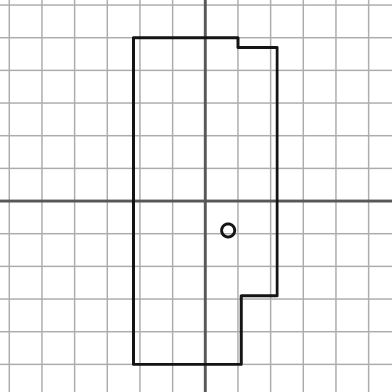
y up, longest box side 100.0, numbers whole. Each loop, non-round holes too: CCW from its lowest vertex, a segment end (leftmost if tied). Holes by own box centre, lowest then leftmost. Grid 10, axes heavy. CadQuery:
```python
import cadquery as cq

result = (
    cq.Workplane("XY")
    .moveTo(-22.0, -50.0)
    .lineTo(11.0, -50.0)
    .lineTo(11.0, -29.0)
    .lineTo(22.0, -29.0)
    .lineTo(22.0, 47.0)
    .lineTo(10.0, 47.0)
    .lineTo(10.0, 50.0)
    .lineTo(-22.0, 50.0)
    .close()
    .moveTo(7.0, -9.0)
    .circle(2.0)
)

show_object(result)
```